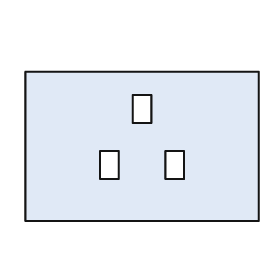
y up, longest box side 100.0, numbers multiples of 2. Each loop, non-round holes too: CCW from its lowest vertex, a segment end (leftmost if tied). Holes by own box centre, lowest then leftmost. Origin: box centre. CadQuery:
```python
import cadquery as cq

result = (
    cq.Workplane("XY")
    .moveTo(-50.0, -32.0)
    .lineTo(50.0, -32.0)
    .lineTo(50.0, 32.0)
    .lineTo(-50.0, 32.0)
    .close()
    .moveTo(-18.0, -14.0)
    .lineTo(-10.0, -14.0)
    .lineTo(-10.0, -2.0)
    .lineTo(-18.0, -2.0)
    .close()
    .moveTo(10.0, -14.0)
    .lineTo(18.0, -14.0)
    .lineTo(18.0, -2.0)
    .lineTo(10.0, -2.0)
    .close()
    .moveTo(-4.0, 10.0)
    .lineTo(4.0, 10.0)
    .lineTo(4.0, 22.0)
    .lineTo(-4.0, 22.0)
    .close()
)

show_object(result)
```